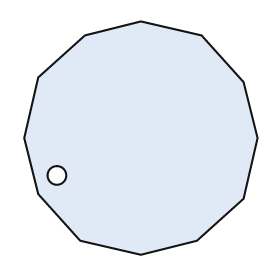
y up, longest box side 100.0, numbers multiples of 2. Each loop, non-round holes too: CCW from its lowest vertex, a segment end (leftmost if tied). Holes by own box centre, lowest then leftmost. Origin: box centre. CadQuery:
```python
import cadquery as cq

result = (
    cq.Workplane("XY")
    .moveTo(0.0, -50.0)
    .lineTo(24.0, -44.0)
    .lineTo(44.0, -26.0)
    .lineTo(50.0, 0.0)
    .lineTo(44.0, 24.0)
    .lineTo(26.0, 44.0)
    .lineTo(0.0, 50.0)
    .lineTo(-24.0, 44.0)
    .lineTo(-44.0, 26.0)
    .lineTo(-50.0, 0.0)
    .lineTo(-44.0, -24.0)
    .lineTo(-26.0, -44.0)
    .close()
    .moveTo(-36.0, -16.0)
    .circle(4.0)
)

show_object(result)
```